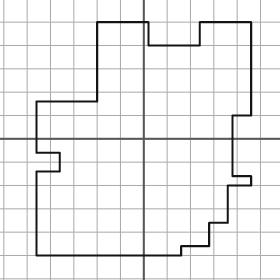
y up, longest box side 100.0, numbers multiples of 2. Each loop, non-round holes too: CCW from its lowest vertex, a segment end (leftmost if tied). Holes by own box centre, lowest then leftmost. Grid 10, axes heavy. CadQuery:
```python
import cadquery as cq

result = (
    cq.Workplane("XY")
    .moveTo(-46.0, -50.0)
    .lineTo(16.0, -50.0)
    .lineTo(16.0, -46.0)
    .lineTo(28.0, -46.0)
    .lineTo(28.0, -36.0)
    .lineTo(36.0, -36.0)
    .lineTo(36.0, -20.0)
    .lineTo(46.0, -20.0)
    .lineTo(46.0, -16.0)
    .lineTo(38.0, -16.0)
    .lineTo(38.0, 10.0)
    .lineTo(46.0, 10.0)
    .lineTo(46.0, 50.0)
    .lineTo(24.0, 50.0)
    .lineTo(24.0, 40.0)
    .lineTo(2.0, 40.0)
    .lineTo(2.0, 50.0)
    .lineTo(-20.0, 50.0)
    .lineTo(-20.0, 16.0)
    .lineTo(-46.0, 16.0)
    .lineTo(-46.0, -6.0)
    .lineTo(-36.0, -6.0)
    .lineTo(-36.0, -14.0)
    .lineTo(-46.0, -14.0)
    .close()
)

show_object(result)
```